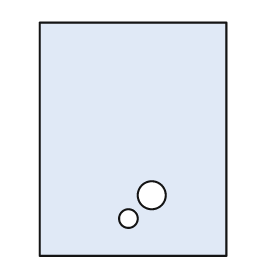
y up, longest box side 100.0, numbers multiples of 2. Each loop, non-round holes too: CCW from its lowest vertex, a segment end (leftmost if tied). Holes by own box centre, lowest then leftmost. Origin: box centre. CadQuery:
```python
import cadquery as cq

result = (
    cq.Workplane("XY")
    .moveTo(-40.0, -50.0)
    .lineTo(40.0, -50.0)
    .lineTo(40.0, 50.0)
    .lineTo(-40.0, 50.0)
    .close()
    .moveTo(-2.0, -34.0)
    .circle(4.0)
    .moveTo(8.0, -24.0)
    .circle(6.0)
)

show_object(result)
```